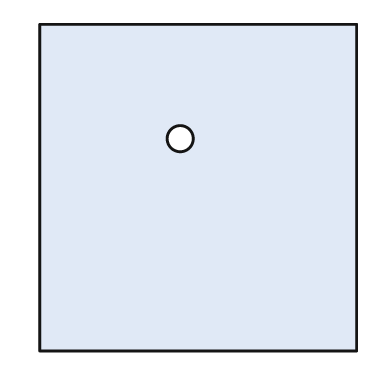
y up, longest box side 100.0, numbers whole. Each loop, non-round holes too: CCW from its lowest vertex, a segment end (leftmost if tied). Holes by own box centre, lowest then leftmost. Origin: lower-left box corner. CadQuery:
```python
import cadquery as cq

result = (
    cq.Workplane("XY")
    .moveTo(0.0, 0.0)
    .lineTo(97.0, 0.0)
    .lineTo(97.0, 100.0)
    .lineTo(0.0, 100.0)
    .close()
    .moveTo(43.0, 65.0)
    .circle(4.0)
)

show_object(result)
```